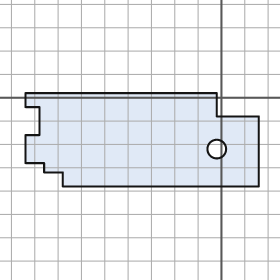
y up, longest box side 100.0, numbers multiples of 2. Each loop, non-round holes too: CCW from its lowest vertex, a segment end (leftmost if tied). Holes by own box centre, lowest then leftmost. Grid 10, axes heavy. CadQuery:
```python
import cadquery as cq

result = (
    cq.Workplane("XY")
    .moveTo(-68.0, -38.0)
    .lineTo(16.0, -38.0)
    .lineTo(16.0, -8.0)
    .lineTo(-2.0, -8.0)
    .lineTo(-2.0, 2.0)
    .lineTo(-84.0, 2.0)
    .lineTo(-84.0, -4.0)
    .lineTo(-78.0, -4.0)
    .lineTo(-78.0, -16.0)
    .lineTo(-84.0, -16.0)
    .lineTo(-84.0, -28.0)
    .lineTo(-76.0, -28.0)
    .lineTo(-76.0, -32.0)
    .lineTo(-68.0, -32.0)
    .close()
    .moveTo(-2.0, -22.0)
    .circle(4.0)
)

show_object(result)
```